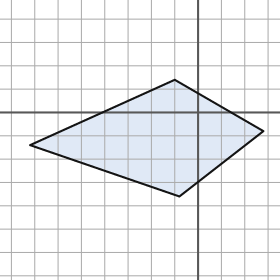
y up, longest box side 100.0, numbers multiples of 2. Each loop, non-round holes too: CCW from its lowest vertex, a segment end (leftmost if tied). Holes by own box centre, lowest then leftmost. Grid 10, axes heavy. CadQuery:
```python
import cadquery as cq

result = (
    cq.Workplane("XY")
    .moveTo(-8.0, -36.0)
    .lineTo(28.0, -8.0)
    .lineTo(-10.0, 14.0)
    .lineTo(-72.0, -14.0)
    .close()
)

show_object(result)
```